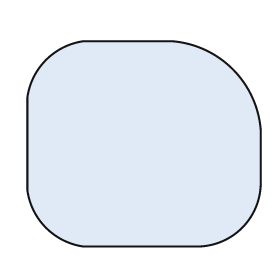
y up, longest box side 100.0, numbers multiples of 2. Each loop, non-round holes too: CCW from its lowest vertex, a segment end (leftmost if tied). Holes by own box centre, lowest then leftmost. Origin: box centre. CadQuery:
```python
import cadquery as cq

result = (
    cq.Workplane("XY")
    .moveTo(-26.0, -44.0)
    .lineTo(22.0, -44.0)
    .threePointArc((42.0, -36.0), (50.0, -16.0))
    .lineTo(50.0, 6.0)
    .threePointArc((38.0, 32.0), (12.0, 44.0))
    .lineTo(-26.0, 44.0)
    .threePointArc((-42.0, 36.0), (-50.0, 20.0))
    .lineTo(-50.0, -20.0)
    .threePointArc((-42.0, -36.0), (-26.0, -44.0))
    .close()
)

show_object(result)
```